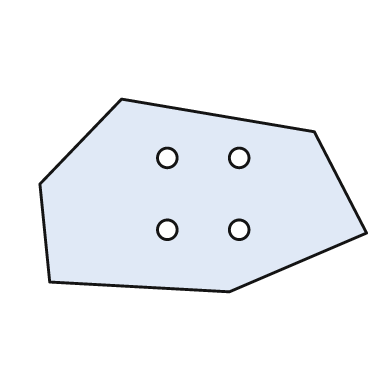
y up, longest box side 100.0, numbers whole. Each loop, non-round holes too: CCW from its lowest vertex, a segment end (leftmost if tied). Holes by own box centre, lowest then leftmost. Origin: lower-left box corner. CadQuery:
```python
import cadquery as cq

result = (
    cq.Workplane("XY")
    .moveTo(58.0, 0.0)
    .lineTo(100.0, 18.0)
    .lineTo(84.0, 49.0)
    .lineTo(25.0, 59.0)
    .lineTo(0.0, 33.0)
    .lineTo(3.0, 3.0)
    .close()
    .moveTo(39.0, 19.0)
    .circle(3.0)
    .moveTo(61.0, 19.0)
    .circle(3.0)
    .moveTo(39.0, 41.0)
    .circle(3.0)
    .moveTo(61.0, 41.0)
    .circle(3.0)
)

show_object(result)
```